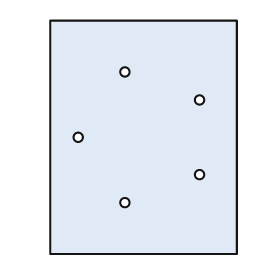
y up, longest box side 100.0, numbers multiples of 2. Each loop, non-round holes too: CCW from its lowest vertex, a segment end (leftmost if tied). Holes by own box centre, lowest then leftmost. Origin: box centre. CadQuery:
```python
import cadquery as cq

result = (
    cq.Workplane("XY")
    .moveTo(-40.0, -50.0)
    .lineTo(40.0, -50.0)
    .lineTo(40.0, 50.0)
    .lineTo(-40.0, 50.0)
    .close()
    .moveTo(-8.0, -28.0)
    .circle(2.0)
    .moveTo(24.0, -16.0)
    .circle(2.0)
    .moveTo(-28.0, 0.0)
    .circle(2.0)
    .moveTo(24.0, 16.0)
    .circle(2.0)
    .moveTo(-8.0, 28.0)
    .circle(2.0)
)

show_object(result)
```